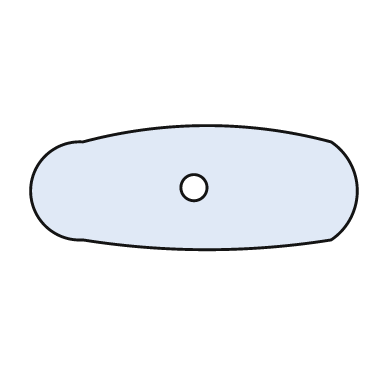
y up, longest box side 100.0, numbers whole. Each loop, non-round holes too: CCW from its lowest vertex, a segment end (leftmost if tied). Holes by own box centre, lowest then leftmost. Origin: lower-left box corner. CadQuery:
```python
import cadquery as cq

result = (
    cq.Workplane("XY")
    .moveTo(16.0, 3.0)
    .threePointArc((54.0, 0.0), (92.0, 3.0))
    .threePointArc((100.0, 18.0), (92.0, 33.0))
    .threePointArc((54.0, 38.0), (16.0, 33.0))
    .threePointArc((0.0, 18.0), (16.0, 3.0))
    .close()
    .moveTo(50.0, 19.0)
    .circle(4.0)
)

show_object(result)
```